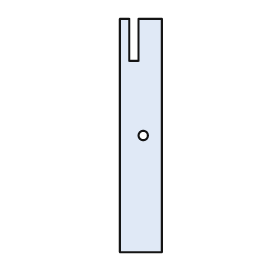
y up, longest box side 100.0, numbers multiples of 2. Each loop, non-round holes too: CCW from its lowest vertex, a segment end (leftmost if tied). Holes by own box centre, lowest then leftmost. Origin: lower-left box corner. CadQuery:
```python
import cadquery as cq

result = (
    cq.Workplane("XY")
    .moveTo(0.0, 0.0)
    .lineTo(18.0, 0.0)
    .lineTo(18.0, 100.0)
    .lineTo(8.0, 100.0)
    .lineTo(8.0, 82.0)
    .lineTo(4.0, 82.0)
    .lineTo(4.0, 100.0)
    .lineTo(0.0, 100.0)
    .close()
    .moveTo(10.0, 50.0)
    .circle(2.0)
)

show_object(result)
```